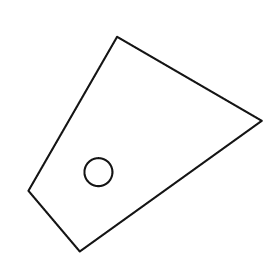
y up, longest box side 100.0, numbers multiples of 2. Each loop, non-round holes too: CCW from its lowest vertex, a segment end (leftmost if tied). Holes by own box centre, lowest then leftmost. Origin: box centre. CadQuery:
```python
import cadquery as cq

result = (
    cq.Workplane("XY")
    .moveTo(-28.0, -46.0)
    .lineTo(50.0, 10.0)
    .lineTo(-12.0, 46.0)
    .lineTo(-50.0, -20.0)
    .close()
    .moveTo(-20.0, -12.0)
    .circle(6.0)
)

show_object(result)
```